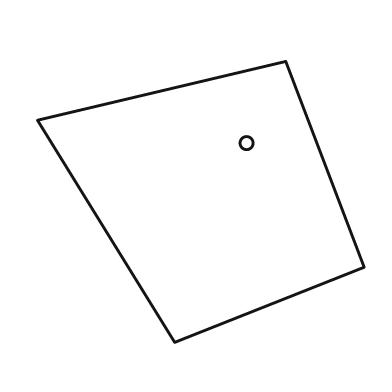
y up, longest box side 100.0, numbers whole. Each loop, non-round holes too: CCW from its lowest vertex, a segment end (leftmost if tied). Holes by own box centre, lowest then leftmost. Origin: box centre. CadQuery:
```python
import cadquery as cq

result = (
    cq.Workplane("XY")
    .moveTo(-8.0, -43.0)
    .lineTo(50.0, -20.0)
    .lineTo(26.0, 43.0)
    .lineTo(-50.0, 25.0)
    .close()
    .moveTo(14.0, 18.0)
    .circle(2.0)
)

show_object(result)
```